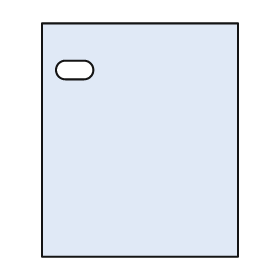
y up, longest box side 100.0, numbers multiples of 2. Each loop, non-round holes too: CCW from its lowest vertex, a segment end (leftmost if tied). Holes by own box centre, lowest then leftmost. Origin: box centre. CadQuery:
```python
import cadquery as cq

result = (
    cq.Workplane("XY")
    .moveTo(-42.0, -50.0)
    .lineTo(42.0, -50.0)
    .lineTo(42.0, 50.0)
    .lineTo(-42.0, 50.0)
    .close()
    .moveTo(-32.0, 26.0)
    .lineTo(-24.0, 26.0)
    .threePointArc((-20.0, 30.0), (-24.0, 34.0))
    .lineTo(-32.0, 34.0)
    .threePointArc((-36.0, 30.0), (-32.0, 26.0))
    .close()
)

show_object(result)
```